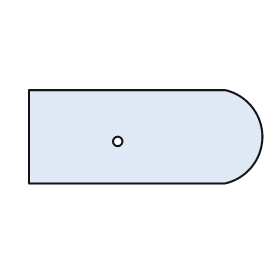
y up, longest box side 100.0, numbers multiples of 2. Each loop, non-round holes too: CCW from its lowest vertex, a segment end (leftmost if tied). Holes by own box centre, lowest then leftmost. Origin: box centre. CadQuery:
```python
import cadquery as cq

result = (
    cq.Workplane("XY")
    .moveTo(-50.0, -20.0)
    .lineTo(34.0, -20.0)
    .threePointArc((50.0, 0.0), (34.0, 20.0))
    .lineTo(-50.0, 20.0)
    .close()
    .moveTo(-12.0, -2.0)
    .circle(2.0)
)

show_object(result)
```